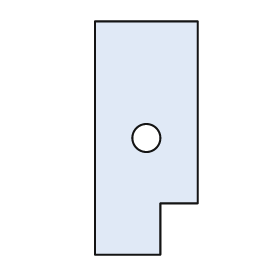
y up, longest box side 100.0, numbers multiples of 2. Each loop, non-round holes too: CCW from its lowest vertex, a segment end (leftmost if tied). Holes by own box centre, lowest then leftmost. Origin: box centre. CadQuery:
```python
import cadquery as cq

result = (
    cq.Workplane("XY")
    .moveTo(-22.0, -50.0)
    .lineTo(6.0, -50.0)
    .lineTo(6.0, -28.0)
    .lineTo(22.0, -28.0)
    .lineTo(22.0, 50.0)
    .lineTo(-22.0, 50.0)
    .close()
    .moveTo(0.0, 0.0)
    .circle(6.0)
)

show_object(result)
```